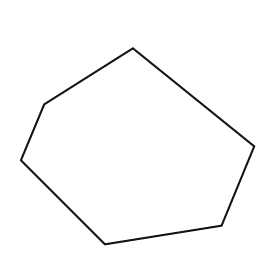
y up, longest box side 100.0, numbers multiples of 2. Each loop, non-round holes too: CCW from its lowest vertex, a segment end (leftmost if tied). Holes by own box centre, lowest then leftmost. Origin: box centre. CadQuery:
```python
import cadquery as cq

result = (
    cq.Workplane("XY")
    .moveTo(-14.0, -42.0)
    .lineTo(36.0, -34.0)
    .lineTo(50.0, 0.0)
    .lineTo(-2.0, 42.0)
    .lineTo(-40.0, 18.0)
    .lineTo(-50.0, -6.0)
    .close()
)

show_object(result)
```